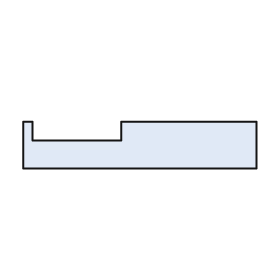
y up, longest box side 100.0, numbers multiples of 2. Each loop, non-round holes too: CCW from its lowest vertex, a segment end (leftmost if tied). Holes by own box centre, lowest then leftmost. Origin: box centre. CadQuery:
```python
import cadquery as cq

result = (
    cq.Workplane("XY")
    .moveTo(-50.0, -10.0)
    .lineTo(50.0, -10.0)
    .lineTo(50.0, 10.0)
    .lineTo(-8.0, 10.0)
    .lineTo(-8.0, 2.0)
    .lineTo(-46.0, 2.0)
    .lineTo(-46.0, 10.0)
    .lineTo(-50.0, 10.0)
    .close()
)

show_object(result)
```